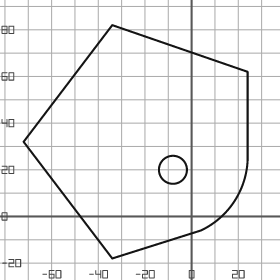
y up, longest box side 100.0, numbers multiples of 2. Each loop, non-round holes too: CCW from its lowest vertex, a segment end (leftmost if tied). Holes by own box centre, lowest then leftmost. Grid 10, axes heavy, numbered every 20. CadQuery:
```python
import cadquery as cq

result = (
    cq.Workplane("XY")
    .moveTo(-34.0, -18.0)
    .lineTo(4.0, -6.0)
    .threePointArc((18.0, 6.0), (24.0, 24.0))
    .lineTo(24.0, 62.0)
    .lineTo(-34.0, 82.0)
    .lineTo(-72.0, 32.0)
    .close()
    .moveTo(-8.0, 20.0)
    .circle(6.0)
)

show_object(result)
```